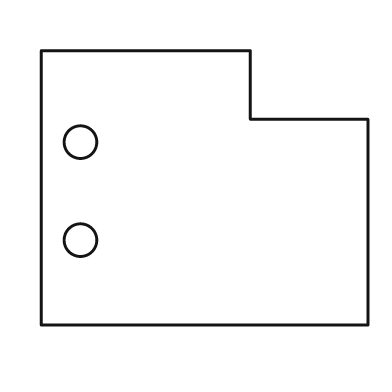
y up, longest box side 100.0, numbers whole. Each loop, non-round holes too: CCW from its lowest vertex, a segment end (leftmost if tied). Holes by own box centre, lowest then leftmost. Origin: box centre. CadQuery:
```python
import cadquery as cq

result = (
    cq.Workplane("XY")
    .moveTo(-50.0, -42.0)
    .lineTo(50.0, -42.0)
    .lineTo(50.0, 21.0)
    .lineTo(14.0, 21.0)
    .lineTo(14.0, 42.0)
    .lineTo(-50.0, 42.0)
    .close()
    .moveTo(-38.0, -16.0)
    .circle(5.0)
    .moveTo(-38.0, 14.0)
    .circle(5.0)
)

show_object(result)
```